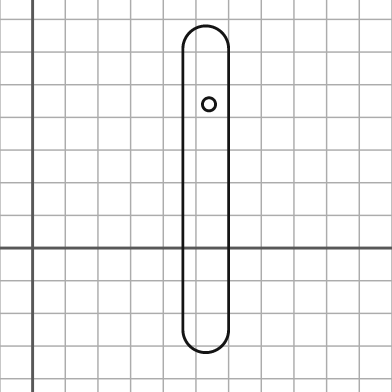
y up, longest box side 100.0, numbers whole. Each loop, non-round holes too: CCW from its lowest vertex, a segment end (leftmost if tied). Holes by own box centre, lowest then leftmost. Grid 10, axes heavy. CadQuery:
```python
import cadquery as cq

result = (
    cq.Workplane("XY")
    .moveTo(46.0, -25.0)
    .threePointArc((53.0, -32.0), (60.0, -25.0))
    .lineTo(60.0, 61.0)
    .threePointArc((53.0, 68.0), (46.0, 61.0))
    .close()
    .moveTo(54.0, 44.0)
    .circle(2.0)
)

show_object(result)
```